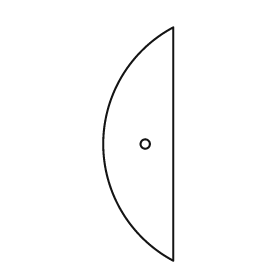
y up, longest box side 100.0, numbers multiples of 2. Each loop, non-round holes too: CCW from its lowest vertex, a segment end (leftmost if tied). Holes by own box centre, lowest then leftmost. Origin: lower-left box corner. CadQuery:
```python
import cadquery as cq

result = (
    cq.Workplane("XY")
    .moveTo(30.0, 0.0)
    .lineTo(30.0, 100.0)
    .threePointArc((0.0, 50.0), (30.0, 0.0))
    .close()
    .moveTo(18.0, 50.0)
    .circle(2.0)
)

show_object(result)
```